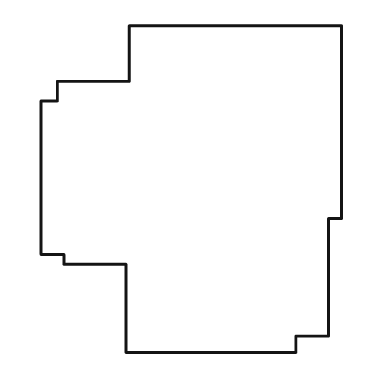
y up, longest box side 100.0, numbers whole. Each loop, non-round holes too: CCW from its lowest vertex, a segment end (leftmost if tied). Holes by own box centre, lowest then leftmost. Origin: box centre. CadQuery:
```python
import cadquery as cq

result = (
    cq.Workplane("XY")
    .moveTo(-20.0, -50.0)
    .lineTo(32.0, -50.0)
    .lineTo(32.0, -45.0)
    .lineTo(42.0, -45.0)
    .lineTo(42.0, -9.0)
    .lineTo(46.0, -9.0)
    .lineTo(46.0, 50.0)
    .lineTo(-19.0, 50.0)
    .lineTo(-19.0, 33.0)
    .lineTo(-41.0, 33.0)
    .lineTo(-41.0, 27.0)
    .lineTo(-46.0, 27.0)
    .lineTo(-46.0, -20.0)
    .lineTo(-39.0, -20.0)
    .lineTo(-39.0, -23.0)
    .lineTo(-20.0, -23.0)
    .close()
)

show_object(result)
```